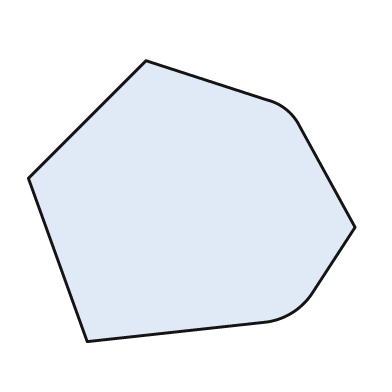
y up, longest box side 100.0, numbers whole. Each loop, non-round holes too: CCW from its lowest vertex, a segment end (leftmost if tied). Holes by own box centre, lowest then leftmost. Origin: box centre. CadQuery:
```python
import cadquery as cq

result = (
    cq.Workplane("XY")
    .moveTo(-32.0, -43.0)
    .lineTo(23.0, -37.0)
    .threePointArc((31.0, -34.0), (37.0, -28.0))
    .lineTo(50.0, -8.0)
    .lineTo(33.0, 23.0)
    .threePointArc((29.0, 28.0), (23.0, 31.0))
    .lineTo(-14.0, 43.0)
    .lineTo(-50.0, 7.0)
    .close()
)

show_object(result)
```